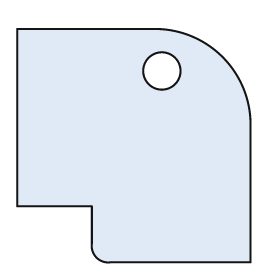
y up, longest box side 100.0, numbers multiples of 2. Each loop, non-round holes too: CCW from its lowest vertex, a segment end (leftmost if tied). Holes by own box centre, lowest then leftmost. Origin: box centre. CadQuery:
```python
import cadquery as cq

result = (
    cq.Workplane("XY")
    .moveTo(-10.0, -50.0)
    .lineTo(50.0, -50.0)
    .lineTo(50.0, 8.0)
    .threePointArc((38.0, 38.0), (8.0, 50.0))
    .lineTo(-50.0, 50.0)
    .lineTo(-50.0, -26.0)
    .lineTo(-18.0, -26.0)
    .lineTo(-18.0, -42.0)
    .threePointArc((-16.0, -48.0), (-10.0, -50.0))
    .close()
    .moveTo(12.0, 32.0)
    .circle(8.0)
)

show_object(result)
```